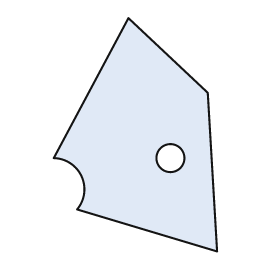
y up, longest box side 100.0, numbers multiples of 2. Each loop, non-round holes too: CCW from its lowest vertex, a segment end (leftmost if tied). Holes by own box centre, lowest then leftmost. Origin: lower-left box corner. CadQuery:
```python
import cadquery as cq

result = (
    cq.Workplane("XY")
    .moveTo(70.0, 0.0)
    .lineTo(66.0, 68.0)
    .lineTo(32.0, 100.0)
    .lineTo(0.0, 40.0)
    .threePointArc((12.0, 32.0), (10.0, 18.0))
    .close()
    .moveTo(50.0, 40.0)
    .circle(6.0)
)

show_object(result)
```